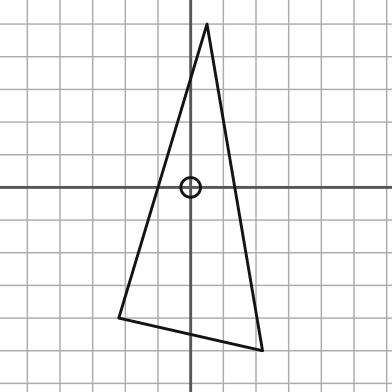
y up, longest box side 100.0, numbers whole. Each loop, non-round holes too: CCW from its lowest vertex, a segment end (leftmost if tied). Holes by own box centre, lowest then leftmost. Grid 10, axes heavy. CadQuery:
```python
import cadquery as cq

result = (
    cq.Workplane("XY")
    .moveTo(22.0, -50.0)
    .lineTo(5.0, 50.0)
    .lineTo(-22.0, -40.0)
    .close()
    .moveTo(0.0, 0.0)
    .circle(3.0)
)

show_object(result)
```